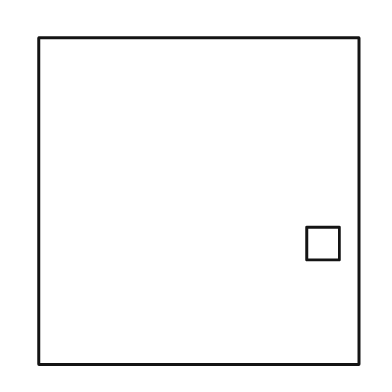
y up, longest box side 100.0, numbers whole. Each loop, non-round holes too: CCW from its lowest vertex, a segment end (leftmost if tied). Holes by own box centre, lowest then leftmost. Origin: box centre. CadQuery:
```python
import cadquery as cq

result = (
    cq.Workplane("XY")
    .moveTo(-49.0, -50.0)
    .lineTo(49.0, -50.0)
    .lineTo(49.0, 50.0)
    .lineTo(-49.0, 50.0)
    .close()
    .moveTo(33.0, -18.0)
    .lineTo(43.0, -18.0)
    .lineTo(43.0, -8.0)
    .lineTo(33.0, -8.0)
    .close()
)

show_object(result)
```